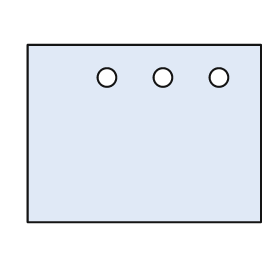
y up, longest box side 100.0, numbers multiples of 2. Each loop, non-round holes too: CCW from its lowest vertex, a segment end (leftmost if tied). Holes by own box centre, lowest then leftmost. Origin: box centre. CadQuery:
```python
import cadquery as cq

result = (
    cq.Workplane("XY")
    .moveTo(-50.0, -38.0)
    .lineTo(50.0, -38.0)
    .lineTo(50.0, 38.0)
    .lineTo(-50.0, 38.0)
    .close()
    .moveTo(-16.0, 24.0)
    .circle(4.0)
    .moveTo(8.0, 24.0)
    .circle(4.0)
    .moveTo(32.0, 24.0)
    .circle(4.0)
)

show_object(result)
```